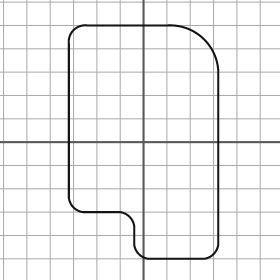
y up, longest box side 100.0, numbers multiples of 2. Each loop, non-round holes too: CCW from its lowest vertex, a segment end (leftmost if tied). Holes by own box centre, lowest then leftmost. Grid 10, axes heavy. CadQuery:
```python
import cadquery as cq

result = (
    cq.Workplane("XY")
    .moveTo(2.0, -50.0)
    .lineTo(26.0, -50.0)
    .threePointArc((30.0, -48.0), (32.0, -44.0))
    .lineTo(32.0, 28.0)
    .threePointArc((26.0, 44.0), (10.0, 50.0))
    .lineTo(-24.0, 50.0)
    .threePointArc((-30.0, 48.0), (-32.0, 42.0))
    .lineTo(-32.0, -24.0)
    .threePointArc((-30.0, -28.0), (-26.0, -30.0))
    .lineTo(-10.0, -30.0)
    .threePointArc((-6.0, -32.0), (-4.0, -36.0))
    .lineTo(-4.0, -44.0)
    .threePointArc((-2.0, -48.0), (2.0, -50.0))
    .close()
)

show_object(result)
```